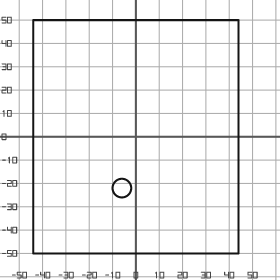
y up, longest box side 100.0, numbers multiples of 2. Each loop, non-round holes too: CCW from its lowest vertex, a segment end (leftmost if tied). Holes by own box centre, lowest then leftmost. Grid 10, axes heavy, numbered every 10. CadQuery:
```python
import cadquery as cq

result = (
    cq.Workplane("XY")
    .moveTo(-44.0, -50.0)
    .lineTo(44.0, -50.0)
    .lineTo(44.0, 50.0)
    .lineTo(-44.0, 50.0)
    .close()
    .moveTo(-6.0, -22.0)
    .circle(4.0)
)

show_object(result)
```